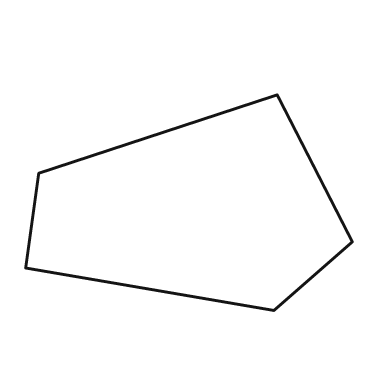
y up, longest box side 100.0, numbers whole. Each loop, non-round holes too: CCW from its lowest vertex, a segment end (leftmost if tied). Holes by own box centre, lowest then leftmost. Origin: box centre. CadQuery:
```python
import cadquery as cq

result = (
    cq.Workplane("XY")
    .moveTo(26.0, -33.0)
    .lineTo(50.0, -12.0)
    .lineTo(27.0, 33.0)
    .lineTo(-46.0, 9.0)
    .lineTo(-50.0, -20.0)
    .close()
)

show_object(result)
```